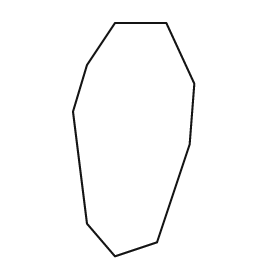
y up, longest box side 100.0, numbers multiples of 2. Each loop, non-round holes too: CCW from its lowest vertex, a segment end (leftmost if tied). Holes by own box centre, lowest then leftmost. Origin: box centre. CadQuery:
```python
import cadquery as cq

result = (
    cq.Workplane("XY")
    .moveTo(-8.0, -50.0)
    .lineTo(10.0, -44.0)
    .lineTo(24.0, -2.0)
    .lineTo(26.0, 24.0)
    .lineTo(14.0, 50.0)
    .lineTo(-8.0, 50.0)
    .lineTo(-20.0, 32.0)
    .lineTo(-26.0, 12.0)
    .lineTo(-20.0, -36.0)
    .close()
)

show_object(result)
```